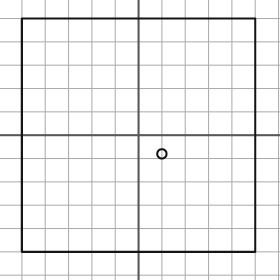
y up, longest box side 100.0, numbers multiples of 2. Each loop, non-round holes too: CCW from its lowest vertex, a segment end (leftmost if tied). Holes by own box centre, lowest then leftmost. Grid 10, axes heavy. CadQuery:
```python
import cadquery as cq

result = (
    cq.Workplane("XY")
    .moveTo(-50.0, -50.0)
    .lineTo(50.0, -50.0)
    .lineTo(50.0, 50.0)
    .lineTo(-50.0, 50.0)
    .close()
    .moveTo(10.0, -8.0)
    .circle(2.0)
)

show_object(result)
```